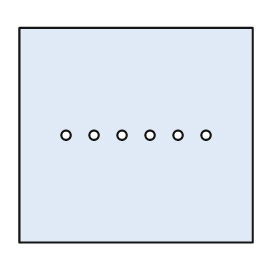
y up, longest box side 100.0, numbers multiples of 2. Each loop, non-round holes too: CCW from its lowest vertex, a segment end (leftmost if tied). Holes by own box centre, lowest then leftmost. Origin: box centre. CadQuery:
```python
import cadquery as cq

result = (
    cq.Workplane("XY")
    .moveTo(-50.0, -46.0)
    .lineTo(50.0, -46.0)
    .lineTo(50.0, 46.0)
    .lineTo(-50.0, 46.0)
    .close()
    .moveTo(-30.0, 0.0)
    .circle(2.0)
    .moveTo(-18.0, 0.0)
    .circle(2.0)
    .moveTo(-6.0, 0.0)
    .circle(2.0)
    .moveTo(6.0, 0.0)
    .circle(2.0)
    .moveTo(18.0, 0.0)
    .circle(2.0)
    .moveTo(30.0, 0.0)
    .circle(2.0)
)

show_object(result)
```